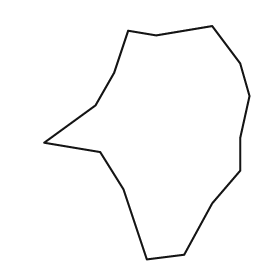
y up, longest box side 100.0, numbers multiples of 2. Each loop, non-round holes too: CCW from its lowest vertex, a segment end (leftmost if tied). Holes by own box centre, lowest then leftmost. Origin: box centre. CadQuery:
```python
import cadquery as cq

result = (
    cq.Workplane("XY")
    .moveTo(0.0, -50.0)
    .lineTo(16.0, -48.0)
    .lineTo(28.0, -26.0)
    .lineTo(40.0, -12.0)
    .lineTo(40.0, 2.0)
    .lineTo(44.0, 20.0)
    .lineTo(40.0, 34.0)
    .lineTo(28.0, 50.0)
    .lineTo(4.0, 46.0)
    .lineTo(-8.0, 48.0)
    .lineTo(-14.0, 30.0)
    .lineTo(-22.0, 16.0)
    .lineTo(-44.0, 0.0)
    .lineTo(-20.0, -4.0)
    .lineTo(-10.0, -20.0)
    .close()
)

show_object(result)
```